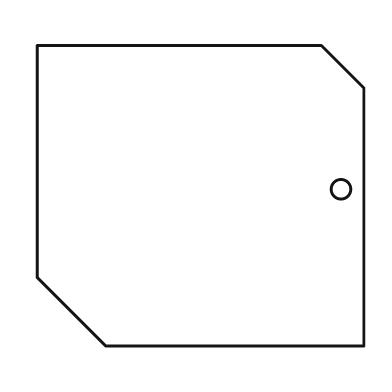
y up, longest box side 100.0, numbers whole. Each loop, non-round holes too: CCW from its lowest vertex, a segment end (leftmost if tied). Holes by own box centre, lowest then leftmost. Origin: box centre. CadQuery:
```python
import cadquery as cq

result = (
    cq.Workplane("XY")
    .moveTo(-29.0, -46.0)
    .lineTo(50.0, -46.0)
    .lineTo(50.0, 33.0)
    .lineTo(37.0, 46.0)
    .lineTo(-50.0, 46.0)
    .lineTo(-50.0, -25.0)
    .close()
    .moveTo(43.0, 2.0)
    .circle(3.0)
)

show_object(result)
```